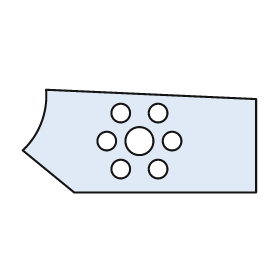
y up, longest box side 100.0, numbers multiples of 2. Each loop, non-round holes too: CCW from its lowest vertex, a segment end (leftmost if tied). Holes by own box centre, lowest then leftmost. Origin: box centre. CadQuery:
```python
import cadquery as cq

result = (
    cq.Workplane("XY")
    .moveTo(-28.0, -22.0)
    .lineTo(50.0, -22.0)
    .lineTo(50.0, 18.0)
    .lineTo(-40.0, 22.0)
    .threePointArc((-42.0, 8.0), (-50.0, -4.0))
    .close()
    .moveTo(-8.0, -12.0)
    .circle(4.0)
    .moveTo(8.0, -12.0)
    .circle(4.0)
    .moveTo(-14.0, 0.0)
    .circle(4.0)
    .moveTo(0.0, 0.0)
    .circle(6.0)
    .moveTo(14.0, 0.0)
    .circle(4.0)
    .moveTo(-8.0, 12.0)
    .circle(4.0)
    .moveTo(8.0, 12.0)
    .circle(4.0)
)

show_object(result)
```